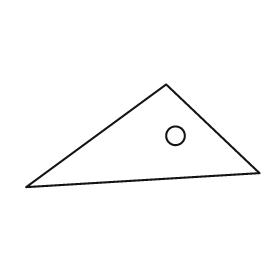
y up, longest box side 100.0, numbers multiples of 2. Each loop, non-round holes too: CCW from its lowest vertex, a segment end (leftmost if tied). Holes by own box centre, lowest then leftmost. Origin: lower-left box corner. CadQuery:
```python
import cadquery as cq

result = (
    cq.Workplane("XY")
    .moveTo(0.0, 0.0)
    .lineTo(100.0, 6.0)
    .lineTo(60.0, 44.0)
    .close()
    .moveTo(64.0, 22.0)
    .circle(4.0)
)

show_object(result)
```